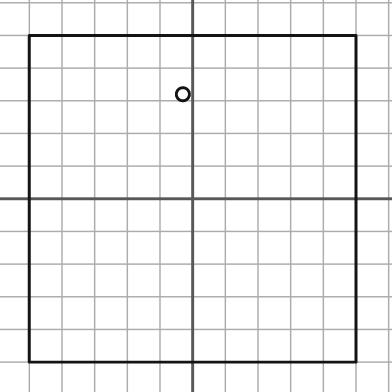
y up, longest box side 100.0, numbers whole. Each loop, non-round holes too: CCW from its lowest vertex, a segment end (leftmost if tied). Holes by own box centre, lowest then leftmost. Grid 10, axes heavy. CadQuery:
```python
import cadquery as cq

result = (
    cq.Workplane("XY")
    .moveTo(-50.0, -50.0)
    .lineTo(50.0, -50.0)
    .lineTo(50.0, 50.0)
    .lineTo(-50.0, 50.0)
    .close()
    .moveTo(-3.0, 32.0)
    .circle(2.0)
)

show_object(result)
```